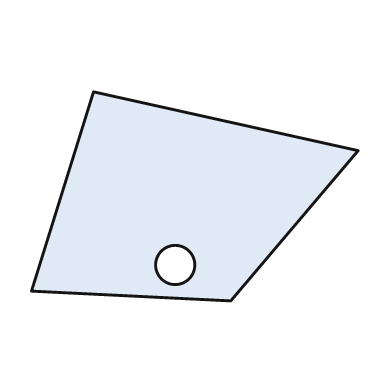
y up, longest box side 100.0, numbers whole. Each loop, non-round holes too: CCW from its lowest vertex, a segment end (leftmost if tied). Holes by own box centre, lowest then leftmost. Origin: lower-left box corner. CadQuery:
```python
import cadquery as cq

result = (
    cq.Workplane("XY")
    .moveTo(61.0, 0.0)
    .lineTo(100.0, 46.0)
    .lineTo(19.0, 64.0)
    .lineTo(0.0, 3.0)
    .close()
    .moveTo(44.0, 11.0)
    .circle(6.0)
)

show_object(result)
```